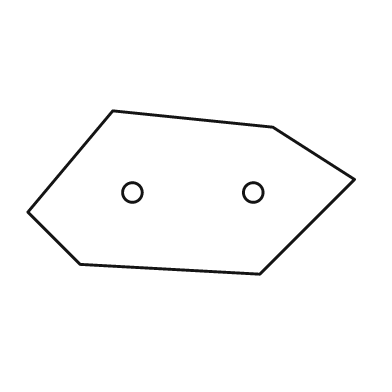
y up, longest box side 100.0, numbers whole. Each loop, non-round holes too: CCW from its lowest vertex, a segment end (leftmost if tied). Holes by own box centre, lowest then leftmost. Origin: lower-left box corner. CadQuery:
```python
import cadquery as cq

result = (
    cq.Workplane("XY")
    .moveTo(71.0, 0.0)
    .lineTo(100.0, 29.0)
    .lineTo(75.0, 45.0)
    .lineTo(26.0, 50.0)
    .lineTo(0.0, 19.0)
    .lineTo(16.0, 3.0)
    .close()
    .moveTo(32.0, 25.0)
    .circle(3.0)
    .moveTo(69.0, 25.0)
    .circle(3.0)
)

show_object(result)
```